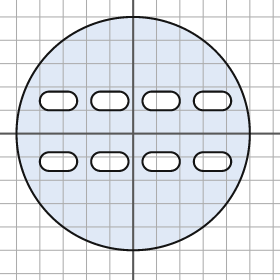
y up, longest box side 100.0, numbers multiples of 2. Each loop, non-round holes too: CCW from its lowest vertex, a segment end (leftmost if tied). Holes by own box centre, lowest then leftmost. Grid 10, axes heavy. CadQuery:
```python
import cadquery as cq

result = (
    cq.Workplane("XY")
    .moveTo(0.0, 0.0)
    .circle(50.0)
    .moveTo(-36.0, -16.0)
    .lineTo(-28.0, -16.0)
    .threePointArc((-24.0, -12.0), (-28.0, -8.0))
    .lineTo(-36.0, -8.0)
    .threePointArc((-40.0, -12.0), (-36.0, -16.0))
    .close()
    .moveTo(-14.0, -16.0)
    .lineTo(-6.0, -16.0)
    .threePointArc((-2.0, -12.0), (-6.0, -8.0))
    .lineTo(-14.0, -8.0)
    .threePointArc((-18.0, -12.0), (-14.0, -16.0))
    .close()
    .moveTo(8.0, -16.0)
    .lineTo(16.0, -16.0)
    .threePointArc((20.0, -12.0), (16.0, -8.0))
    .lineTo(8.0, -8.0)
    .threePointArc((4.0, -12.0), (8.0, -16.0))
    .close()
    .moveTo(30.0, -16.0)
    .lineTo(38.0, -16.0)
    .threePointArc((42.0, -12.0), (38.0, -8.0))
    .lineTo(30.0, -8.0)
    .threePointArc((26.0, -12.0), (30.0, -16.0))
    .close()
    .moveTo(-36.0, 10.0)
    .lineTo(-28.0, 10.0)
    .threePointArc((-24.0, 14.0), (-28.0, 18.0))
    .lineTo(-36.0, 18.0)
    .threePointArc((-40.0, 14.0), (-36.0, 10.0))
    .close()
    .moveTo(-14.0, 10.0)
    .lineTo(-6.0, 10.0)
    .threePointArc((-2.0, 14.0), (-6.0, 18.0))
    .lineTo(-14.0, 18.0)
    .threePointArc((-18.0, 14.0), (-14.0, 10.0))
    .close()
    .moveTo(8.0, 10.0)
    .lineTo(16.0, 10.0)
    .threePointArc((20.0, 14.0), (16.0, 18.0))
    .lineTo(8.0, 18.0)
    .threePointArc((4.0, 14.0), (8.0, 10.0))
    .close()
    .moveTo(30.0, 10.0)
    .lineTo(38.0, 10.0)
    .threePointArc((42.0, 14.0), (38.0, 18.0))
    .lineTo(30.0, 18.0)
    .threePointArc((26.0, 14.0), (30.0, 10.0))
    .close()
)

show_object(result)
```